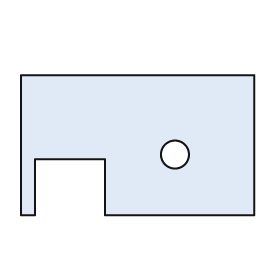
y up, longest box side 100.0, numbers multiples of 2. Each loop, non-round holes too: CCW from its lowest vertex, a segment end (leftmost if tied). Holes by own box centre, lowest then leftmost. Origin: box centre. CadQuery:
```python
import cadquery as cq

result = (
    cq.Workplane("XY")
    .moveTo(-50.0, -30.0)
    .lineTo(-44.0, -30.0)
    .lineTo(-44.0, -6.0)
    .lineTo(-14.0, -6.0)
    .lineTo(-14.0, -30.0)
    .lineTo(50.0, -30.0)
    .lineTo(50.0, 30.0)
    .lineTo(-50.0, 30.0)
    .close()
    .moveTo(16.0, -4.0)
    .circle(6.0)
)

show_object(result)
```